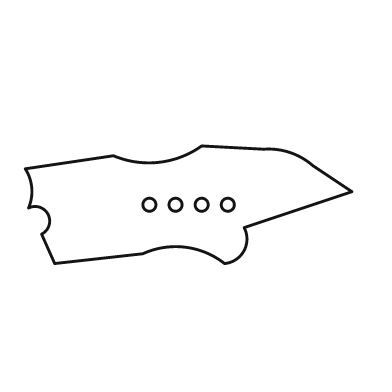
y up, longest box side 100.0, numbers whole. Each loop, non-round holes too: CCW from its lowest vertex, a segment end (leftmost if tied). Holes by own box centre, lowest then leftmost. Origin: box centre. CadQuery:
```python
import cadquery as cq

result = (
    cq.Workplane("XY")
    .moveTo(-41.0, -18.0)
    .lineTo(-14.0, -15.0)
    .threePointArc((-1.0, -13.0), (11.0, -18.0))
    .threePointArc((17.0, -14.0), (17.0, -7.0))
    .lineTo(50.0, 4.0)
    .lineTo(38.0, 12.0)
    .threePointArc((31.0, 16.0), (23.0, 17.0))
    .lineTo(4.0, 18.0)
    .threePointArc((-9.0, 13.0), (-23.0, 15.0))
    .lineTo(-50.0, 11.0)
    .threePointArc((-48.0, 5.0), (-49.0, -1.0))
    .threePointArc((-43.0, -3.0), (-45.0, -9.0))
    .close()
    .moveTo(-12.0, 0.0)
    .circle(2.0)
    .moveTo(-4.0, 0.0)
    .circle(2.0)
    .moveTo(4.0, 0.0)
    .circle(2.0)
    .moveTo(12.0, 0.0)
    .circle(2.0)
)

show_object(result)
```